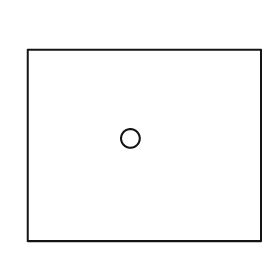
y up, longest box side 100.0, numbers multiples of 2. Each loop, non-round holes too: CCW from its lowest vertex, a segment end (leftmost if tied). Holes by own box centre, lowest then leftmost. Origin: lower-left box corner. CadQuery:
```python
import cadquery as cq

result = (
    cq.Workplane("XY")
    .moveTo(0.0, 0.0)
    .lineTo(100.0, 0.0)
    .lineTo(100.0, 82.0)
    .lineTo(0.0, 82.0)
    .close()
    .moveTo(44.0, 44.0)
    .circle(4.0)
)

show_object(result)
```